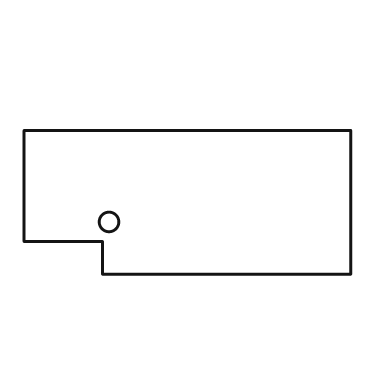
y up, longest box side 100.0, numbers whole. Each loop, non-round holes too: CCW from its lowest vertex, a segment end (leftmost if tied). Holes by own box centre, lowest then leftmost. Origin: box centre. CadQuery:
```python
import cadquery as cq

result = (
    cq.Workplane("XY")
    .moveTo(-26.0, -22.0)
    .lineTo(50.0, -22.0)
    .lineTo(50.0, 22.0)
    .lineTo(-50.0, 22.0)
    .lineTo(-50.0, -12.0)
    .lineTo(-26.0, -12.0)
    .close()
    .moveTo(-24.0, -6.0)
    .circle(3.0)
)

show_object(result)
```